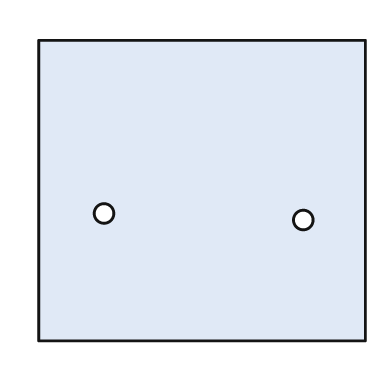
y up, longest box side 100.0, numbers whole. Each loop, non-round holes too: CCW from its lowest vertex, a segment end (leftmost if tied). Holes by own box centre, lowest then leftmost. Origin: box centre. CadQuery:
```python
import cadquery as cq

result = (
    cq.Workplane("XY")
    .moveTo(-50.0, -46.0)
    .lineTo(50.0, -46.0)
    .lineTo(50.0, 46.0)
    .lineTo(-50.0, 46.0)
    .close()
    .moveTo(31.0, -9.0)
    .circle(3.0)
    .moveTo(-30.0, -7.0)
    .circle(3.0)
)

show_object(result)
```